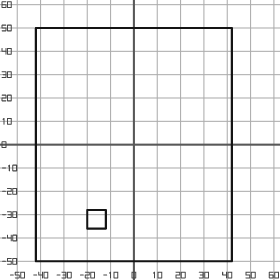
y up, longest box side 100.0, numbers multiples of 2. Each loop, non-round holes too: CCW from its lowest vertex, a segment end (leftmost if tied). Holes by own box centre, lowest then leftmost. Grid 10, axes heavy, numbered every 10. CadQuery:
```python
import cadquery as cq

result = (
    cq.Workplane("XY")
    .moveTo(-42.0, -50.0)
    .lineTo(42.0, -50.0)
    .lineTo(42.0, 50.0)
    .lineTo(-42.0, 50.0)
    .close()
    .moveTo(-20.0, -36.0)
    .lineTo(-12.0, -36.0)
    .lineTo(-12.0, -28.0)
    .lineTo(-20.0, -28.0)
    .close()
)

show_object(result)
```